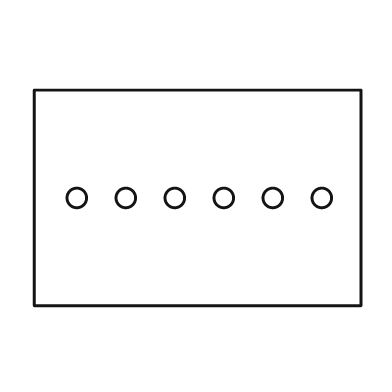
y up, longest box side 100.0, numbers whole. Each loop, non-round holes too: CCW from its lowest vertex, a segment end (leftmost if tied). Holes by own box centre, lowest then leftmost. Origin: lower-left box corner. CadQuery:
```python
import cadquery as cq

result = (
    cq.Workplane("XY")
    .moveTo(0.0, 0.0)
    .lineTo(100.0, 0.0)
    .lineTo(100.0, 66.0)
    .lineTo(0.0, 66.0)
    .close()
    .moveTo(13.0, 33.0)
    .circle(3.0)
    .moveTo(28.0, 33.0)
    .circle(3.0)
    .moveTo(43.0, 33.0)
    .circle(3.0)
    .moveTo(58.0, 33.0)
    .circle(3.0)
    .moveTo(73.0, 33.0)
    .circle(3.0)
    .moveTo(88.0, 33.0)
    .circle(3.0)
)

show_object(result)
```